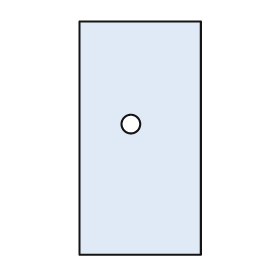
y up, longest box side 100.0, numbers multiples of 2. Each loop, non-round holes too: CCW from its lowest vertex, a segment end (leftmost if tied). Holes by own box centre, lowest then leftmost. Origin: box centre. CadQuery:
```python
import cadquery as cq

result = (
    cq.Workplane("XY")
    .moveTo(-26.0, -50.0)
    .lineTo(26.0, -50.0)
    .lineTo(26.0, 50.0)
    .lineTo(-26.0, 50.0)
    .close()
    .moveTo(-4.0, 6.0)
    .circle(4.0)
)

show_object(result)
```